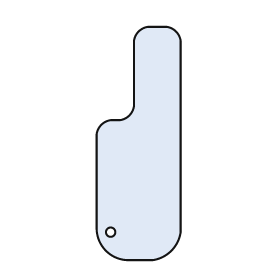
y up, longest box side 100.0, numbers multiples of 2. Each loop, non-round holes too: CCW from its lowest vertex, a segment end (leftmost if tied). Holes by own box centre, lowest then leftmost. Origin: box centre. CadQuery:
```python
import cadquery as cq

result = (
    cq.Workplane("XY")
    .moveTo(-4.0, -50.0)
    .lineTo(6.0, -50.0)
    .threePointArc((14.0, -46.0), (18.0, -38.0))
    .lineTo(18.0, 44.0)
    .threePointArc((16.0, 48.0), (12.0, 50.0))
    .lineTo(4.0, 50.0)
    .threePointArc((0.0, 48.0), (-2.0, 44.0))
    .lineTo(-2.0, 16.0)
    .threePointArc((-4.0, 12.0), (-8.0, 10.0))
    .lineTo(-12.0, 10.0)
    .threePointArc((-16.0, 8.0), (-18.0, 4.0))
    .lineTo(-18.0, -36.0)
    .threePointArc((-14.0, -46.0), (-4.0, -50.0))
    .close()
    .moveTo(-12.0, -38.0)
    .circle(2.0)
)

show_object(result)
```